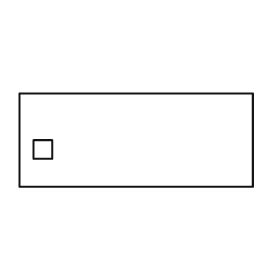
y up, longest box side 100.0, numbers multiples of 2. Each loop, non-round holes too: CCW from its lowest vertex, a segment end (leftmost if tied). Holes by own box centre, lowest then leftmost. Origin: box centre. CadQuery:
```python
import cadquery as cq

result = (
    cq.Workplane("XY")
    .moveTo(-50.0, -20.0)
    .lineTo(50.0, -20.0)
    .lineTo(50.0, 20.0)
    .lineTo(-50.0, 20.0)
    .close()
    .moveTo(-44.0, -8.0)
    .lineTo(-36.0, -8.0)
    .lineTo(-36.0, 0.0)
    .lineTo(-44.0, 0.0)
    .close()
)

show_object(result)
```